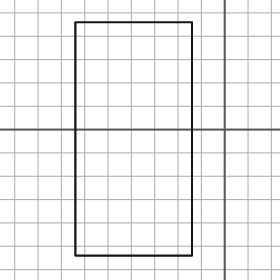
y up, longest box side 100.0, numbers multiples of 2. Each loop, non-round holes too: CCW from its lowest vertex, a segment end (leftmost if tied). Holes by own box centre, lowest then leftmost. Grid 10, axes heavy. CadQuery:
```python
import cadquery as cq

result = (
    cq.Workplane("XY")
    .moveTo(-64.0, -54.0)
    .lineTo(-14.0, -54.0)
    .lineTo(-14.0, 46.0)
    .lineTo(-64.0, 46.0)
    .close()
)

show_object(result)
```